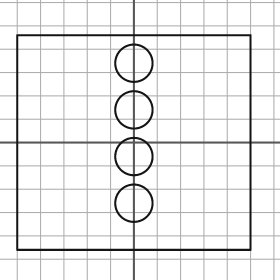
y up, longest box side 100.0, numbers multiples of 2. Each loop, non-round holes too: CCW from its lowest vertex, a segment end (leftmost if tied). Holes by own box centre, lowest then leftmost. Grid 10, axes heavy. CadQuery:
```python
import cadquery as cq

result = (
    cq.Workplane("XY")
    .moveTo(-50.0, -46.0)
    .lineTo(50.0, -46.0)
    .lineTo(50.0, 46.0)
    .lineTo(-50.0, 46.0)
    .close()
    .moveTo(0.0, -26.0)
    .circle(8.0)
    .moveTo(0.0, -6.0)
    .circle(8.0)
    .moveTo(0.0, 14.0)
    .circle(8.0)
    .moveTo(0.0, 34.0)
    .circle(8.0)
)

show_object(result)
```